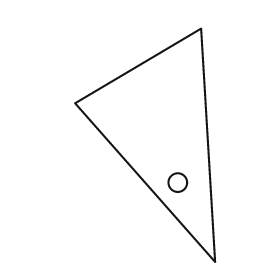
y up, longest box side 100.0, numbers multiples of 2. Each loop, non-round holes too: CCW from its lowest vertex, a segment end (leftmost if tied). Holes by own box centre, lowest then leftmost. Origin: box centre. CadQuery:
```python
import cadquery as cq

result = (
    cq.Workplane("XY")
    .moveTo(30.0, -50.0)
    .lineTo(24.0, 50.0)
    .lineTo(-30.0, 18.0)
    .close()
    .moveTo(14.0, -16.0)
    .circle(4.0)
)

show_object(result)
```